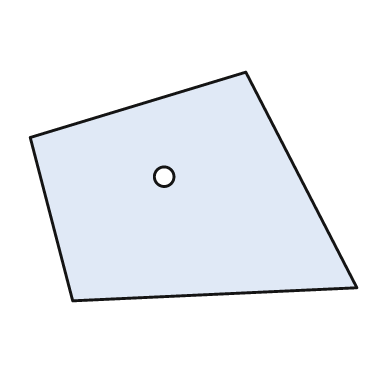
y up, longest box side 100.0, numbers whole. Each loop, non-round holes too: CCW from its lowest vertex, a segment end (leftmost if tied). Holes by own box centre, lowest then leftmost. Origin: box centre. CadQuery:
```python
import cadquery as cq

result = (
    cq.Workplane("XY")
    .moveTo(-37.0, -35.0)
    .lineTo(50.0, -31.0)
    .lineTo(16.0, 35.0)
    .lineTo(-50.0, 15.0)
    .close()
    .moveTo(-9.0, 3.0)
    .circle(3.0)
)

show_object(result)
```